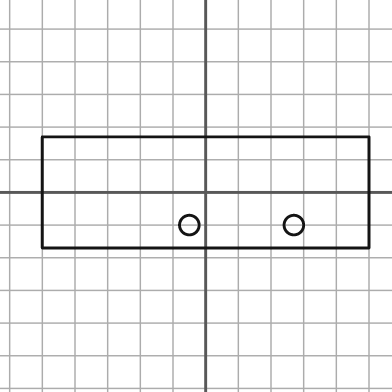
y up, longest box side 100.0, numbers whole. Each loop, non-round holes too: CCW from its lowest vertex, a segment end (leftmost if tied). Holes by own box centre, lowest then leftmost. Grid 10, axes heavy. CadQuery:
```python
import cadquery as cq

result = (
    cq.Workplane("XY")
    .moveTo(-50.0, -17.0)
    .lineTo(50.0, -17.0)
    .lineTo(50.0, 17.0)
    .lineTo(-50.0, 17.0)
    .close()
    .moveTo(-5.0, -10.0)
    .circle(3.0)
    .moveTo(27.0, -10.0)
    .circle(3.0)
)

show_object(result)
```